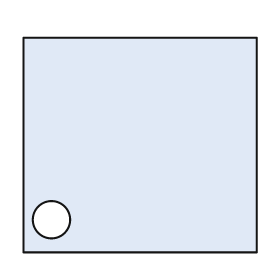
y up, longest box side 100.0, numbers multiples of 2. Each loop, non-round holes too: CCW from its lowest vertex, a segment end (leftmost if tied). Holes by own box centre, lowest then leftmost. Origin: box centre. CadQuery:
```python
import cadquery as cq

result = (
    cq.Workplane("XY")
    .moveTo(-50.0, -46.0)
    .lineTo(50.0, -46.0)
    .lineTo(50.0, 46.0)
    .lineTo(-50.0, 46.0)
    .close()
    .moveTo(-38.0, -32.0)
    .circle(8.0)
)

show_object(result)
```